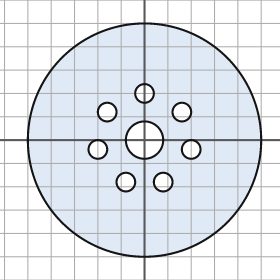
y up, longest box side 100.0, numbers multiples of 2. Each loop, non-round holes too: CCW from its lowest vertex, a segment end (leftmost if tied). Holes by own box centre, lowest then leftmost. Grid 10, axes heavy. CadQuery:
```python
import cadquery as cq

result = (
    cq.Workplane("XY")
    .moveTo(0.0, 0.0)
    .circle(50.0)
    .moveTo(-8.0, -18.0)
    .circle(4.0)
    .moveTo(8.0, -18.0)
    .circle(4.0)
    .moveTo(-20.0, -4.0)
    .circle(4.0)
    .moveTo(20.0, -4.0)
    .circle(4.0)
    .moveTo(0.0, 0.0)
    .circle(8.0)
    .moveTo(-16.0, 12.0)
    .circle(4.0)
    .moveTo(16.0, 12.0)
    .circle(4.0)
    .moveTo(0.0, 20.0)
    .circle(4.0)
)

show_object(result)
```